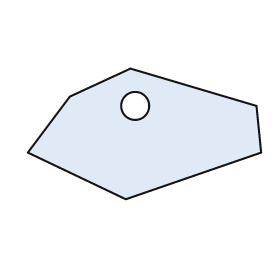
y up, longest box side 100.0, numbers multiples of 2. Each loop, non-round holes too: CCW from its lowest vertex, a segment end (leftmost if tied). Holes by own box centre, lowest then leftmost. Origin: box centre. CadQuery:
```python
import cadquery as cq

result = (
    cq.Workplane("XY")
    .moveTo(-8.0, -28.0)
    .lineTo(50.0, -8.0)
    .lineTo(48.0, 12.0)
    .lineTo(-6.0, 28.0)
    .lineTo(-32.0, 16.0)
    .lineTo(-50.0, -8.0)
    .close()
    .moveTo(-4.0, 12.0)
    .circle(6.0)
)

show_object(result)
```